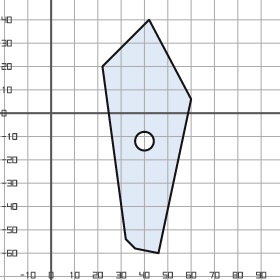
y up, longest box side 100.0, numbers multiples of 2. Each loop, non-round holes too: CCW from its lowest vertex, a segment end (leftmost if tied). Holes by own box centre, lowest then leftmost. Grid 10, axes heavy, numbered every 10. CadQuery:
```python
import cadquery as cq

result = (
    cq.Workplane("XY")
    .moveTo(46.0, -60.0)
    .lineTo(60.0, 6.0)
    .lineTo(42.0, 40.0)
    .lineTo(22.0, 20.0)
    .lineTo(32.0, -54.0)
    .lineTo(36.0, -58.0)
    .close()
    .moveTo(40.0, -12.0)
    .circle(4.0)
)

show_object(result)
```